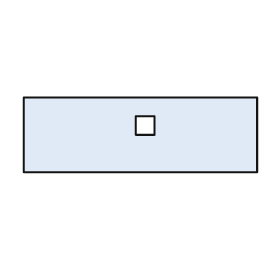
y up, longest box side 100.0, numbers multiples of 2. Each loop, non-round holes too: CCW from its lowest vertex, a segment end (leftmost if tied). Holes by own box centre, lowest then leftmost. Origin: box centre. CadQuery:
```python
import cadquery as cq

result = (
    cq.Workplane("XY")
    .moveTo(-50.0, -16.0)
    .lineTo(50.0, -16.0)
    .lineTo(50.0, 16.0)
    .lineTo(-50.0, 16.0)
    .close()
    .moveTo(-2.0, 0.0)
    .lineTo(6.0, 0.0)
    .lineTo(6.0, 8.0)
    .lineTo(-2.0, 8.0)
    .close()
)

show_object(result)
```